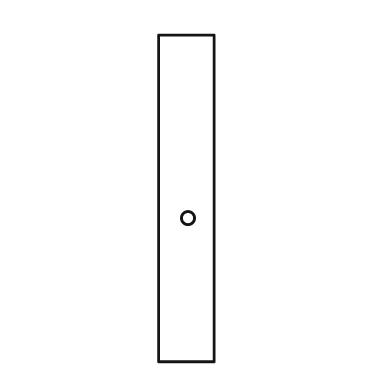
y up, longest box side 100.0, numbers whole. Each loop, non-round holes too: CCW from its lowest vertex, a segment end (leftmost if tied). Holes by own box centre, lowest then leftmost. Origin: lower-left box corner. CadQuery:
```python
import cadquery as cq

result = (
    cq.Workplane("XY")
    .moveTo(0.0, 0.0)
    .lineTo(17.0, 0.0)
    .lineTo(17.0, 100.0)
    .lineTo(0.0, 100.0)
    .close()
    .moveTo(9.0, 44.0)
    .circle(2.0)
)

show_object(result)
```